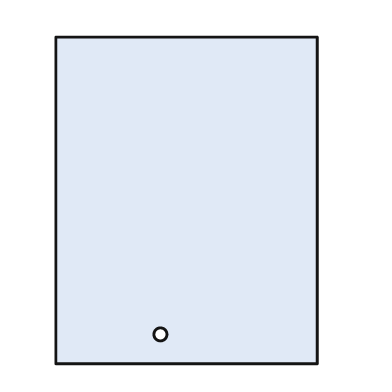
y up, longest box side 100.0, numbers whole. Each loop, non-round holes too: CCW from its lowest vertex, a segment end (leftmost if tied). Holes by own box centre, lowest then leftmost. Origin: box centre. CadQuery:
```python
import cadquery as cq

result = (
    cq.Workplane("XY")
    .moveTo(-40.0, -50.0)
    .lineTo(40.0, -50.0)
    .lineTo(40.0, 50.0)
    .lineTo(-40.0, 50.0)
    .close()
    .moveTo(-8.0, -41.0)
    .circle(2.0)
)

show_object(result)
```